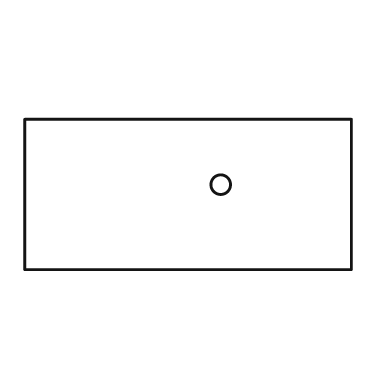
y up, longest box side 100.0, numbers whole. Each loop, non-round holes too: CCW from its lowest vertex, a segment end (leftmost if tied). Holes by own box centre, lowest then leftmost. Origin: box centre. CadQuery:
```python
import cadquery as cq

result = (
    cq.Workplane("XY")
    .moveTo(-50.0, -23.0)
    .lineTo(50.0, -23.0)
    .lineTo(50.0, 23.0)
    .lineTo(-50.0, 23.0)
    .close()
    .moveTo(10.0, 3.0)
    .circle(3.0)
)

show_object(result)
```